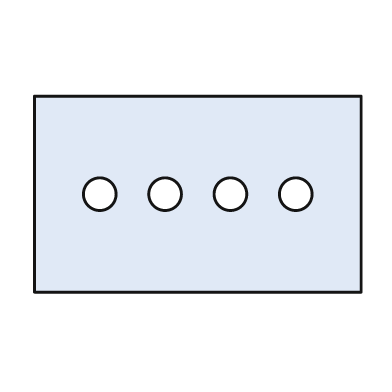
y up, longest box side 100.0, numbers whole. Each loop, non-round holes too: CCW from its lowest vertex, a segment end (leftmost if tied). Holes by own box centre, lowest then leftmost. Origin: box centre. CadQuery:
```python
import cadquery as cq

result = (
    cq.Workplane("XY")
    .moveTo(-50.0, -30.0)
    .lineTo(50.0, -30.0)
    .lineTo(50.0, 30.0)
    .lineTo(-50.0, 30.0)
    .close()
    .moveTo(-30.0, 0.0)
    .circle(5.0)
    .moveTo(-10.0, 0.0)
    .circle(5.0)
    .moveTo(10.0, 0.0)
    .circle(5.0)
    .moveTo(30.0, 0.0)
    .circle(5.0)
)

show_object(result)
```